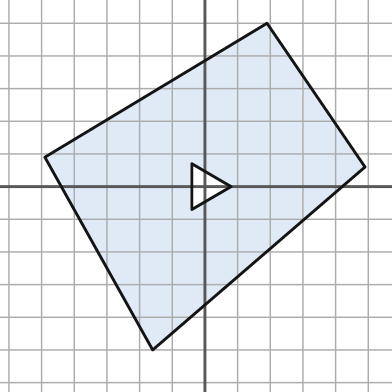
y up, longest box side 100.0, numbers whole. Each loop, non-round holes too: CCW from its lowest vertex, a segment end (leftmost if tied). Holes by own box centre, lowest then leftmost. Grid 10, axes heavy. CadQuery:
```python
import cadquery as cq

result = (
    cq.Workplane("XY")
    .moveTo(-16.0, -50.0)
    .lineTo(49.0, 6.0)
    .lineTo(19.0, 50.0)
    .lineTo(-49.0, 9.0)
    .close()
    .moveTo(-4.0, -7.0)
    .lineTo(8.0, 0.0)
    .lineTo(-4.0, 7.0)
    .close()
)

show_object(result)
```